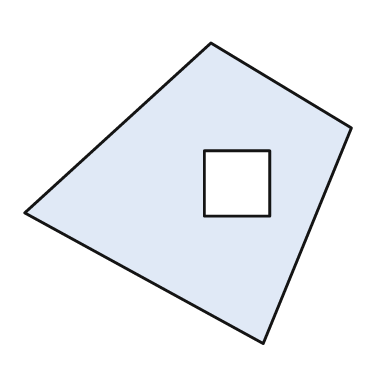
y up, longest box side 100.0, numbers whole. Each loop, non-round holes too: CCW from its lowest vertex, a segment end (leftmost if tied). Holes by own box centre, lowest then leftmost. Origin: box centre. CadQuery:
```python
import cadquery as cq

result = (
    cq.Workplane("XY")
    .moveTo(23.0, -46.0)
    .lineTo(50.0, 20.0)
    .lineTo(7.0, 46.0)
    .lineTo(-50.0, -6.0)
    .close()
    .moveTo(5.0, -7.0)
    .lineTo(25.0, -7.0)
    .lineTo(25.0, 13.0)
    .lineTo(5.0, 13.0)
    .close()
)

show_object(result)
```